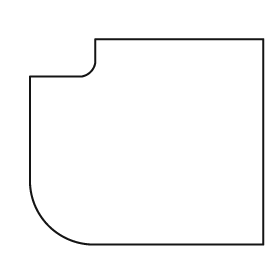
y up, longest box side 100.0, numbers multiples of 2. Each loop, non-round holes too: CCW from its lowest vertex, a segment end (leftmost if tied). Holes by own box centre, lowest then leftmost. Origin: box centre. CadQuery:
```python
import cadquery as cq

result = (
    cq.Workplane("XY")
    .moveTo(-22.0, -44.0)
    .lineTo(50.0, -44.0)
    .lineTo(50.0, 44.0)
    .lineTo(-22.0, 44.0)
    .lineTo(-22.0, 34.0)
    .threePointArc((-24.0, 30.0), (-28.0, 28.0))
    .lineTo(-50.0, 28.0)
    .lineTo(-50.0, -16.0)
    .threePointArc((-42.0, -36.0), (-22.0, -44.0))
    .close()
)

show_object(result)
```